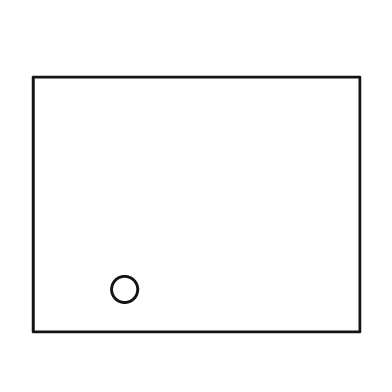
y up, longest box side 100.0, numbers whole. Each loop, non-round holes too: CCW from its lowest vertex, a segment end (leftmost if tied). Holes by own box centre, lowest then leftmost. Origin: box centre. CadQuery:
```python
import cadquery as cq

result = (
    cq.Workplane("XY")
    .moveTo(-50.0, -39.0)
    .lineTo(50.0, -39.0)
    .lineTo(50.0, 39.0)
    .lineTo(-50.0, 39.0)
    .close()
    .moveTo(-22.0, -26.0)
    .circle(4.0)
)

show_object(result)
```